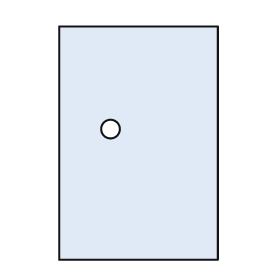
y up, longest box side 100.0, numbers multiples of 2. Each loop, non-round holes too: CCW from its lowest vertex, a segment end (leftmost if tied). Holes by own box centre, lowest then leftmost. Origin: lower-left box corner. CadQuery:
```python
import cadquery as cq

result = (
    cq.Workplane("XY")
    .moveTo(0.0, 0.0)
    .lineTo(68.0, 0.0)
    .lineTo(68.0, 100.0)
    .lineTo(0.0, 100.0)
    .close()
    .moveTo(22.0, 56.0)
    .circle(4.0)
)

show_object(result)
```